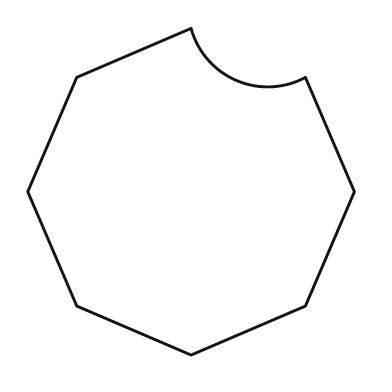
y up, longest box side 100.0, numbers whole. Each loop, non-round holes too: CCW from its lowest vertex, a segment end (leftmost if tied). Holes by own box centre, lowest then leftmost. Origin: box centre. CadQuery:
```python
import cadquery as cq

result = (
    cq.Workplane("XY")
    .moveTo(0.0, -50.0)
    .lineTo(35.0, -35.0)
    .lineTo(50.0, 0.0)
    .lineTo(35.0, 35.0)
    .threePointArc((14.0, 34.0), (0.0, 50.0))
    .lineTo(-35.0, 35.0)
    .lineTo(-50.0, 0.0)
    .lineTo(-35.0, -35.0)
    .close()
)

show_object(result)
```